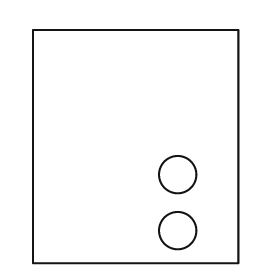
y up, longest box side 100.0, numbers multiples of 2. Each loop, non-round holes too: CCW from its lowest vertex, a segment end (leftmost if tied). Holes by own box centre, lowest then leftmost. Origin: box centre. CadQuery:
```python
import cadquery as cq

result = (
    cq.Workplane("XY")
    .moveTo(-44.0, -50.0)
    .lineTo(44.0, -50.0)
    .lineTo(44.0, 50.0)
    .lineTo(-44.0, 50.0)
    .close()
    .moveTo(18.0, -36.0)
    .circle(8.0)
    .moveTo(18.0, -12.0)
    .circle(8.0)
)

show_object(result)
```